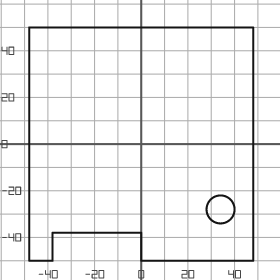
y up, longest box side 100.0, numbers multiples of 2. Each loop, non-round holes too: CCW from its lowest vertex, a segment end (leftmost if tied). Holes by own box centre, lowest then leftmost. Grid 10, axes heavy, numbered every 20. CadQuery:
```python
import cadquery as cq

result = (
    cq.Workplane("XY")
    .moveTo(-48.0, -50.0)
    .lineTo(-38.0, -50.0)
    .lineTo(-38.0, -38.0)
    .lineTo(0.0, -38.0)
    .lineTo(0.0, -50.0)
    .lineTo(48.0, -50.0)
    .lineTo(48.0, 50.0)
    .lineTo(-48.0, 50.0)
    .close()
    .moveTo(34.0, -28.0)
    .circle(6.0)
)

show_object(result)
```